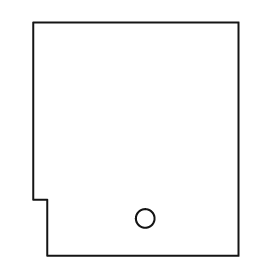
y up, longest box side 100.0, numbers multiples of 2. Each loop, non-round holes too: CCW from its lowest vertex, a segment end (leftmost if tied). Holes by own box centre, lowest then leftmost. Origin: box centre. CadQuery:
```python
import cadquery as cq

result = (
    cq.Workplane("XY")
    .moveTo(-38.0, -50.0)
    .lineTo(44.0, -50.0)
    .lineTo(44.0, 50.0)
    .lineTo(-44.0, 50.0)
    .lineTo(-44.0, -26.0)
    .lineTo(-38.0, -26.0)
    .close()
    .moveTo(4.0, -34.0)
    .circle(4.0)
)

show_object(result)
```